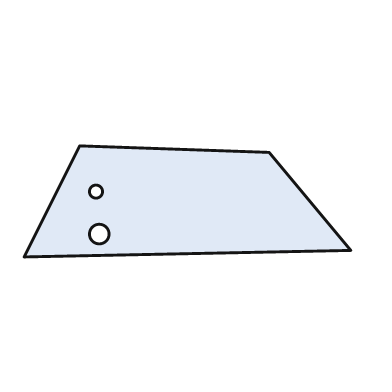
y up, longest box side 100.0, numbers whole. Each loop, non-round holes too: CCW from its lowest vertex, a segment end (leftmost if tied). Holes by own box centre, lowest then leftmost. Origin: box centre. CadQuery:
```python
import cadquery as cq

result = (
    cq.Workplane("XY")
    .moveTo(-50.0, -17.0)
    .lineTo(50.0, -15.0)
    .lineTo(25.0, 15.0)
    .lineTo(-33.0, 17.0)
    .close()
    .moveTo(-27.0, -10.0)
    .circle(3.0)
    .moveTo(-28.0, 3.0)
    .circle(2.0)
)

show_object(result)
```